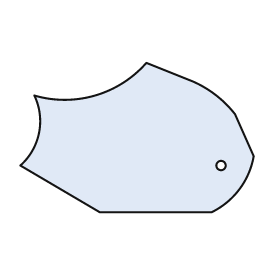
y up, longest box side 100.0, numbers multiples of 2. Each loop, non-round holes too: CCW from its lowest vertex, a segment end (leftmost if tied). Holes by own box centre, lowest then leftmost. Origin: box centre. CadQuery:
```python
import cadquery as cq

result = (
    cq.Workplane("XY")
    .moveTo(-16.0, -32.0)
    .lineTo(32.0, -32.0)
    .threePointArc((44.0, -22.0), (50.0, -8.0))
    .lineTo(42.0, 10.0)
    .threePointArc((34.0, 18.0), (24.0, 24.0))
    .lineTo(4.0, 32.0)
    .threePointArc((-18.0, 18.0), (-44.0, 18.0))
    .threePointArc((-42.0, 2.0), (-50.0, -12.0))
    .close()
    .moveTo(36.0, -12.0)
    .circle(2.0)
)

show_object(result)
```